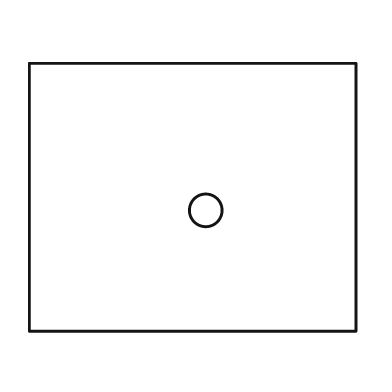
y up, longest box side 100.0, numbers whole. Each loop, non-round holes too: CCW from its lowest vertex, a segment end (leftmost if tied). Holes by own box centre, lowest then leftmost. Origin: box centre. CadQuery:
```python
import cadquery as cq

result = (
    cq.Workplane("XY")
    .moveTo(-50.0, -41.0)
    .lineTo(50.0, -41.0)
    .lineTo(50.0, 41.0)
    .lineTo(-50.0, 41.0)
    .close()
    .moveTo(4.0, -4.0)
    .circle(5.0)
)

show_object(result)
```